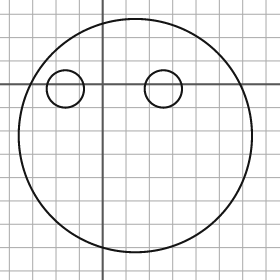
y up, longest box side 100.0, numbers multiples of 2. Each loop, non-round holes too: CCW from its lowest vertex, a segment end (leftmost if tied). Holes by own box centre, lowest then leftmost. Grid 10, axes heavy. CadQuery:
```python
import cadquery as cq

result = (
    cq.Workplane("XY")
    .moveTo(14.0, -22.0)
    .circle(50.0)
    .moveTo(-16.0, -2.0)
    .circle(8.0)
    .moveTo(26.0, -2.0)
    .circle(8.0)
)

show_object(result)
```